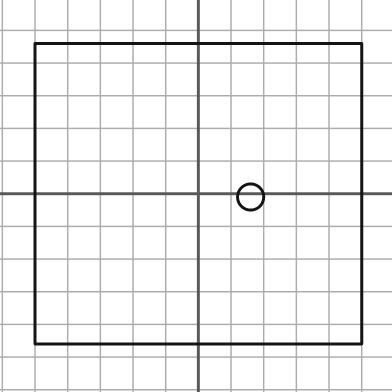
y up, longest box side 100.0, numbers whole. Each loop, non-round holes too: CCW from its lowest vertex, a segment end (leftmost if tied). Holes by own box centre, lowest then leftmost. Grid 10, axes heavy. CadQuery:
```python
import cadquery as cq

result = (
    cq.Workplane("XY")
    .moveTo(-50.0, -46.0)
    .lineTo(50.0, -46.0)
    .lineTo(50.0, 46.0)
    .lineTo(-50.0, 46.0)
    .close()
    .moveTo(16.0, -1.0)
    .circle(4.0)
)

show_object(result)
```